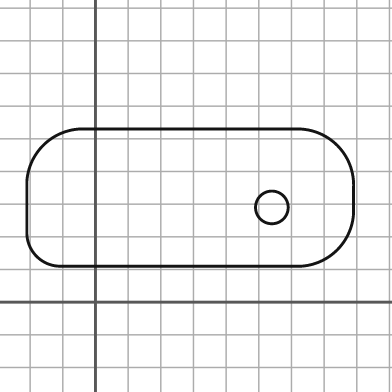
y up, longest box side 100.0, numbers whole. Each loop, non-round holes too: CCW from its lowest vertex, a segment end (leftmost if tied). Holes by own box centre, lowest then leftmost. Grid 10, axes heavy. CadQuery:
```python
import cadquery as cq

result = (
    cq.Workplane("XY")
    .moveTo(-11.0, 11.0)
    .lineTo(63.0, 11.0)
    .threePointArc((74.0, 16.0), (79.0, 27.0))
    .lineTo(79.0, 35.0)
    .threePointArc((74.0, 48.0), (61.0, 53.0))
    .lineTo(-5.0, 53.0)
    .threePointArc((-16.0, 48.0), (-21.0, 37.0))
    .lineTo(-21.0, 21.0)
    .threePointArc((-18.0, 14.0), (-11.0, 11.0))
    .close()
    .moveTo(54.0, 29.0)
    .circle(5.0)
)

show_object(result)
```